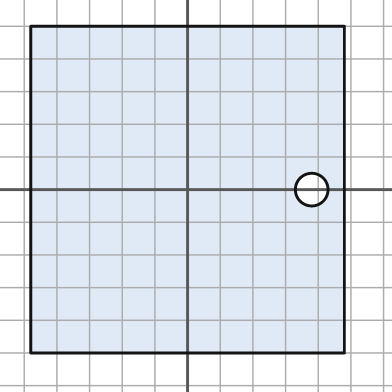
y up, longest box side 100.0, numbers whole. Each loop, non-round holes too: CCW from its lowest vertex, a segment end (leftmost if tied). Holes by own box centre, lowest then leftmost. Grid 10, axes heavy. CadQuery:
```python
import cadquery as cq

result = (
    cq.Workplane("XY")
    .moveTo(-48.0, -50.0)
    .lineTo(48.0, -50.0)
    .lineTo(48.0, 50.0)
    .lineTo(-48.0, 50.0)
    .close()
    .moveTo(38.0, 0.0)
    .circle(5.0)
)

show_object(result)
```